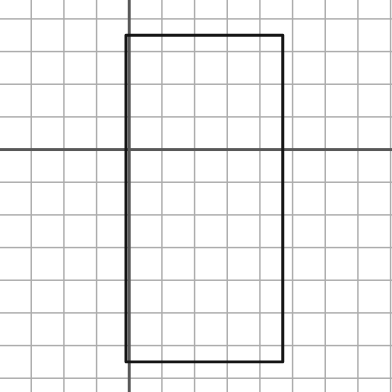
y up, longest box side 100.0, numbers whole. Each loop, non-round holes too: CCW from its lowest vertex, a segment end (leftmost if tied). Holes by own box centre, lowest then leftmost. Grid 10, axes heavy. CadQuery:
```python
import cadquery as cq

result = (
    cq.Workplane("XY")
    .moveTo(-1.0, -65.0)
    .lineTo(47.0, -65.0)
    .lineTo(47.0, 35.0)
    .lineTo(-1.0, 35.0)
    .close()
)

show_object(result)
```